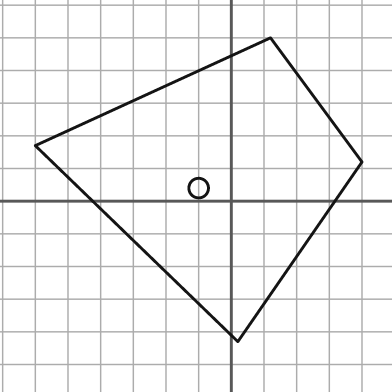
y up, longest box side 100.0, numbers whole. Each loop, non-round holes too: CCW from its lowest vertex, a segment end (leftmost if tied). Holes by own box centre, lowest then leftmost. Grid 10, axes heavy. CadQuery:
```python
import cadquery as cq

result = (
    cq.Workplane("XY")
    .moveTo(2.0, -43.0)
    .lineTo(40.0, 12.0)
    .lineTo(12.0, 50.0)
    .lineTo(-60.0, 17.0)
    .close()
    .moveTo(-10.0, 4.0)
    .circle(3.0)
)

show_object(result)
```